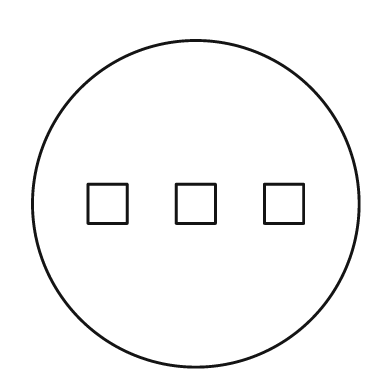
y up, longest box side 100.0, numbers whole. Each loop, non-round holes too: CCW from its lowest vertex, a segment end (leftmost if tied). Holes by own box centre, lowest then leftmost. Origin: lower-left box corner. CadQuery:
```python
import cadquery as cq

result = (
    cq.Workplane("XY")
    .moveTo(50.0, 50.0)
    .circle(50.0)
    .moveTo(17.0, 44.0)
    .lineTo(29.0, 44.0)
    .lineTo(29.0, 56.0)
    .lineTo(17.0, 56.0)
    .close()
    .moveTo(44.0, 44.0)
    .lineTo(56.0, 44.0)
    .lineTo(56.0, 56.0)
    .lineTo(44.0, 56.0)
    .close()
    .moveTo(71.0, 44.0)
    .lineTo(83.0, 44.0)
    .lineTo(83.0, 56.0)
    .lineTo(71.0, 56.0)
    .close()
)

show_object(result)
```